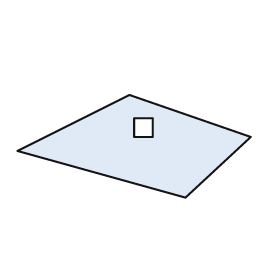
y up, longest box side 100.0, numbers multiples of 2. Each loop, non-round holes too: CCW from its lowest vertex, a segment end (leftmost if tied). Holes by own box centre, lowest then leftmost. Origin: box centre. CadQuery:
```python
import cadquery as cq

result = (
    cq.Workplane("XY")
    .moveTo(22.0, -22.0)
    .lineTo(50.0, 4.0)
    .lineTo(-2.0, 22.0)
    .lineTo(-50.0, -2.0)
    .close()
    .moveTo(0.0, 4.0)
    .lineTo(8.0, 4.0)
    .lineTo(8.0, 12.0)
    .lineTo(0.0, 12.0)
    .close()
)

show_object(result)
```